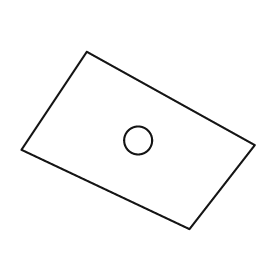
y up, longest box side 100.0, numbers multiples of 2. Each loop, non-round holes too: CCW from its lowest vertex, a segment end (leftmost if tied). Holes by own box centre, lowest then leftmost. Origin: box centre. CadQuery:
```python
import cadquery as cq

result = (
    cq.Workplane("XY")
    .moveTo(22.0, -38.0)
    .lineTo(50.0, -2.0)
    .lineTo(-22.0, 38.0)
    .lineTo(-50.0, -4.0)
    .close()
    .moveTo(0.0, 0.0)
    .circle(6.0)
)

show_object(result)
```